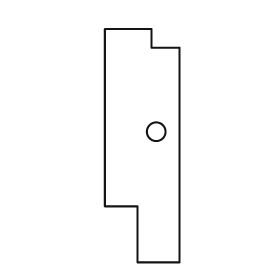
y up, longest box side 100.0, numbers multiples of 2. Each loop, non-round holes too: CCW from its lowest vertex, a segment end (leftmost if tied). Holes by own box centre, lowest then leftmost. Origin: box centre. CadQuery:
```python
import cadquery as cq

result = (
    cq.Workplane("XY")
    .moveTo(-2.0, -50.0)
    .lineTo(16.0, -50.0)
    .lineTo(16.0, 42.0)
    .lineTo(4.0, 42.0)
    .lineTo(4.0, 50.0)
    .lineTo(-16.0, 50.0)
    .lineTo(-16.0, -26.0)
    .lineTo(-2.0, -26.0)
    .close()
    .moveTo(6.0, 6.0)
    .circle(4.0)
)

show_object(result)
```